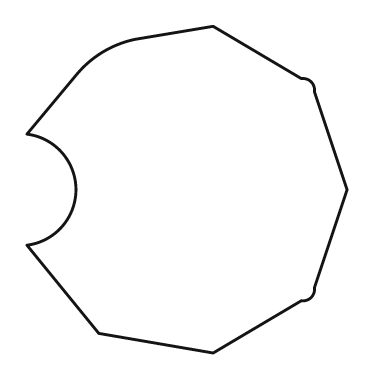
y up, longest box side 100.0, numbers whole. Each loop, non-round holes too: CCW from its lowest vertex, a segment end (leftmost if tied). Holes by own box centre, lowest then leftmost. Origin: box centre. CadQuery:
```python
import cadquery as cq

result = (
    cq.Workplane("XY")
    .moveTo(8.0, -50.0)
    .lineTo(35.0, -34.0)
    .threePointArc((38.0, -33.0), (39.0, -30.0))
    .lineTo(49.0, 0.0)
    .lineTo(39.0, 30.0)
    .threePointArc((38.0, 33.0), (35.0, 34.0))
    .lineTo(8.0, 50.0)
    .lineTo(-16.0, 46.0)
    .threePointArc((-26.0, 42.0), (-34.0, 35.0))
    .lineTo(-49.0, 17.0)
    .threePointArc((-34.0, 0.0), (-49.0, -17.0))
    .lineTo(-27.0, -44.0)
    .close()
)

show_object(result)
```